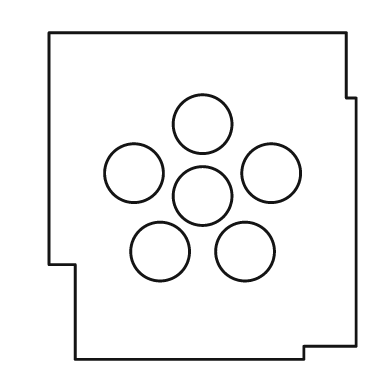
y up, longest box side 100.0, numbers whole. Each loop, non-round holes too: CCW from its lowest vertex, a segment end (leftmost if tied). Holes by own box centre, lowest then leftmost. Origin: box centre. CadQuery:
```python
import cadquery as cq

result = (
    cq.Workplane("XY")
    .moveTo(-39.0, -50.0)
    .lineTo(31.0, -50.0)
    .lineTo(31.0, -46.0)
    .lineTo(47.0, -46.0)
    .lineTo(47.0, 30.0)
    .lineTo(44.0, 30.0)
    .lineTo(44.0, 50.0)
    .lineTo(-47.0, 50.0)
    .lineTo(-47.0, -21.0)
    .lineTo(-39.0, -21.0)
    .close()
    .moveTo(-13.0, -17.0)
    .circle(9.0)
    .moveTo(13.0, -17.0)
    .circle(9.0)
    .moveTo(0.0, 0.0)
    .circle(9.0)
    .moveTo(-21.0, 7.0)
    .circle(9.0)
    .moveTo(21.0, 7.0)
    .circle(9.0)
    .moveTo(0.0, 22.0)
    .circle(9.0)
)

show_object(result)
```